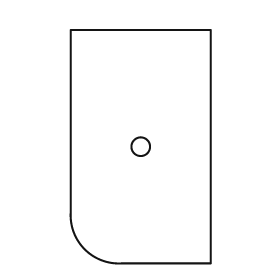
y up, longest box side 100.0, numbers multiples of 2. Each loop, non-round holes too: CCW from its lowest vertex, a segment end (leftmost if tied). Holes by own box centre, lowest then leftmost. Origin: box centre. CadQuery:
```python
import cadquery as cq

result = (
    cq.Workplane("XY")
    .moveTo(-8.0, -50.0)
    .lineTo(30.0, -50.0)
    .lineTo(30.0, 50.0)
    .lineTo(-30.0, 50.0)
    .lineTo(-30.0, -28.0)
    .threePointArc((-24.0, -44.0), (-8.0, -50.0))
    .close()
    .moveTo(0.0, 0.0)
    .circle(4.0)
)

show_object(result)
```